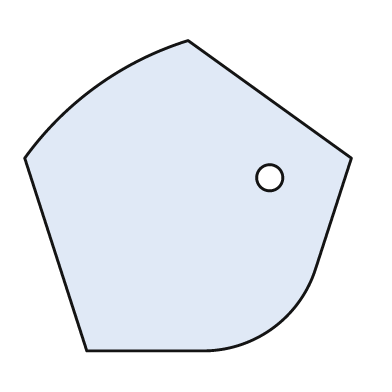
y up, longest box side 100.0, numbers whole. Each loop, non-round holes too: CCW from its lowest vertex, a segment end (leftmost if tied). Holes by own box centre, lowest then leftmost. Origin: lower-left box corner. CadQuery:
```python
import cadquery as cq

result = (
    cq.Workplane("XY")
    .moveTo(19.0, 0.0)
    .lineTo(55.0, 0.0)
    .threePointArc((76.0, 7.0), (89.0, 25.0))
    .lineTo(100.0, 59.0)
    .lineTo(50.0, 95.0)
    .threePointArc((22.0, 81.0), (0.0, 59.0))
    .close()
    .moveTo(75.0, 53.0)
    .circle(4.0)
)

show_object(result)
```